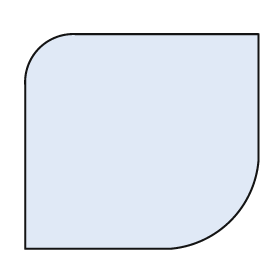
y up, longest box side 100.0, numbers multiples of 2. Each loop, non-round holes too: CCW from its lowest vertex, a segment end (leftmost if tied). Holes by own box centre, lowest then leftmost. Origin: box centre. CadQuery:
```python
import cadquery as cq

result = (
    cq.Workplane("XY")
    .moveTo(-50.0, -46.0)
    .lineTo(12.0, -46.0)
    .threePointArc((38.0, -34.0), (50.0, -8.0))
    .lineTo(50.0, 46.0)
    .lineTo(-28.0, 46.0)
    .threePointArc((-44.0, 40.0), (-50.0, 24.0))
    .close()
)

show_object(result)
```